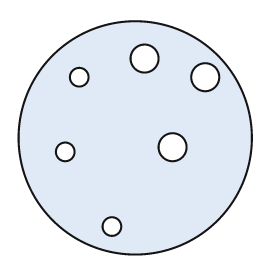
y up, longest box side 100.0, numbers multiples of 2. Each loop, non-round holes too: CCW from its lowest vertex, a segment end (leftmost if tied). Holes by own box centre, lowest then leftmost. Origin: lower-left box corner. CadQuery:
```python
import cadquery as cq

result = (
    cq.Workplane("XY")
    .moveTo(50.0, 50.0)
    .circle(50.0)
    .moveTo(40.0, 12.0)
    .circle(4.0)
    .moveTo(20.0, 44.0)
    .circle(4.0)
    .moveTo(66.0, 46.0)
    .circle(6.0)
    .moveTo(26.0, 76.0)
    .circle(4.0)
    .moveTo(80.0, 76.0)
    .circle(6.0)
    .moveTo(54.0, 84.0)
    .circle(6.0)
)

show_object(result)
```